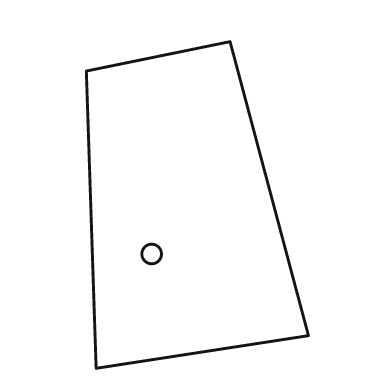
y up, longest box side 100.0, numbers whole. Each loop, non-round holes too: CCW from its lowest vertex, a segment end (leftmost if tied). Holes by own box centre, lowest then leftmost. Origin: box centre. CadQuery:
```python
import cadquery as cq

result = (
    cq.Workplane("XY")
    .moveTo(-31.0, -50.0)
    .lineTo(34.0, -40.0)
    .lineTo(10.0, 50.0)
    .lineTo(-34.0, 41.0)
    .close()
    .moveTo(-14.0, -15.0)
    .circle(3.0)
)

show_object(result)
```